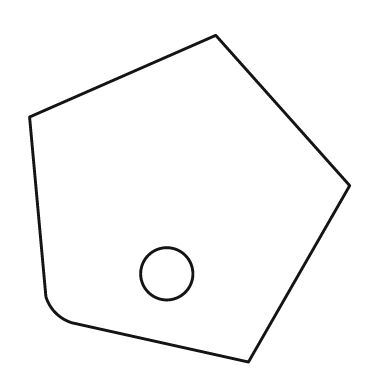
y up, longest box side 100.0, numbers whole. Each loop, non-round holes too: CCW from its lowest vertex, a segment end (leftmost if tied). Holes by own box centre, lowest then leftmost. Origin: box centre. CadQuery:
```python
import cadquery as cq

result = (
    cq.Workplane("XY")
    .moveTo(18.0, -50.0)
    .lineTo(49.0, 4.0)
    .lineTo(8.0, 50.0)
    .lineTo(-49.0, 25.0)
    .lineTo(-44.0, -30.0)
    .threePointArc((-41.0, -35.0), (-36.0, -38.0))
    .close()
    .moveTo(-7.0, -23.0)
    .circle(8.0)
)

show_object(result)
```